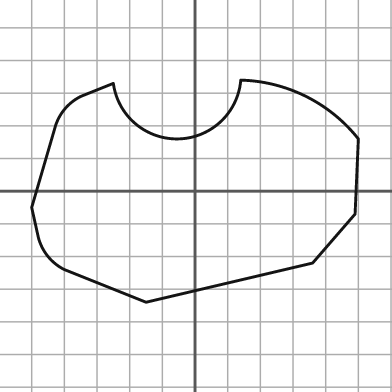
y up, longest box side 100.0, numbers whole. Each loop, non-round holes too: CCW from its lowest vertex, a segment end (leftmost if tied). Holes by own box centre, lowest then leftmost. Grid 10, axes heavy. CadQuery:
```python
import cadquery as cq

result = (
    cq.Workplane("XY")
    .moveTo(-15.0, -34.0)
    .lineTo(36.0, -22.0)
    .lineTo(49.0, -7.0)
    .lineTo(50.0, 16.0)
    .threePointArc((34.0, 29.0), (14.0, 34.0))
    .threePointArc((-5.0, 16.0), (-25.0, 33.0))
    .lineTo(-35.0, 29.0)
    .threePointArc((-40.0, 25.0), (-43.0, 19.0))
    .lineTo(-50.0, -5.0)
    .lineTo(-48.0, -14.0)
    .threePointArc((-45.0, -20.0), (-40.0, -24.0))
    .close()
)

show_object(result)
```